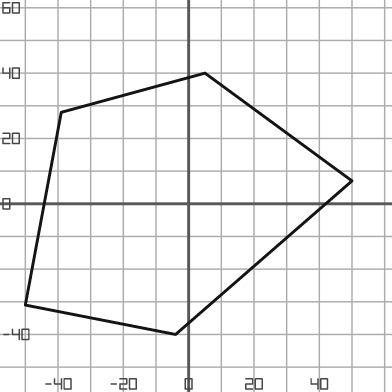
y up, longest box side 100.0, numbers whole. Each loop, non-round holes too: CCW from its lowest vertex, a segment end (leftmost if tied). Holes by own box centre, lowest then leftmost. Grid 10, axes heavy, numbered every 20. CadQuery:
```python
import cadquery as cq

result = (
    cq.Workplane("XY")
    .moveTo(-4.0, -40.0)
    .lineTo(50.0, 7.0)
    .lineTo(5.0, 40.0)
    .lineTo(-39.0, 28.0)
    .lineTo(-50.0, -31.0)
    .close()
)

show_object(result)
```